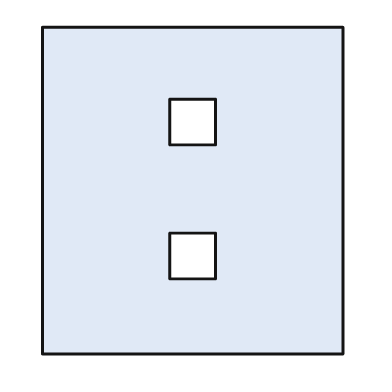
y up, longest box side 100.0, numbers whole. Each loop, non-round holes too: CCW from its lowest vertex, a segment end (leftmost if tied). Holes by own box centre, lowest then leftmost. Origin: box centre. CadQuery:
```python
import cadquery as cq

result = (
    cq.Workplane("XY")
    .moveTo(-46.0, -50.0)
    .lineTo(46.0, -50.0)
    .lineTo(46.0, 50.0)
    .lineTo(-46.0, 50.0)
    .close()
    .moveTo(-7.0, -27.0)
    .lineTo(7.0, -27.0)
    .lineTo(7.0, -13.0)
    .lineTo(-7.0, -13.0)
    .close()
    .moveTo(-7.0, 14.0)
    .lineTo(7.0, 14.0)
    .lineTo(7.0, 28.0)
    .lineTo(-7.0, 28.0)
    .close()
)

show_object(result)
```